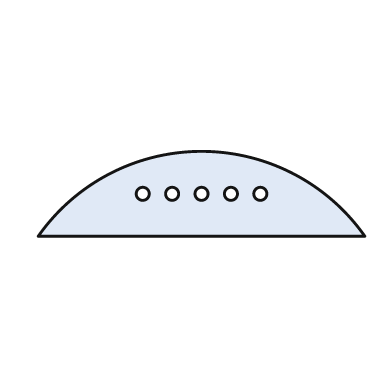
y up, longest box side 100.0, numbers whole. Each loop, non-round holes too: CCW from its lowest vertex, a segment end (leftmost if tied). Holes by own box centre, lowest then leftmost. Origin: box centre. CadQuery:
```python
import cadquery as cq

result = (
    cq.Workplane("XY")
    .moveTo(-50.0, -13.0)
    .lineTo(50.0, -13.0)
    .threePointArc((0.0, 13.0), (-50.0, -13.0))
    .close()
    .moveTo(-18.0, 0.0)
    .circle(2.0)
    .moveTo(-9.0, 0.0)
    .circle(2.0)
    .moveTo(0.0, 0.0)
    .circle(2.0)
    .moveTo(9.0, 0.0)
    .circle(2.0)
    .moveTo(18.0, 0.0)
    .circle(2.0)
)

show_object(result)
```